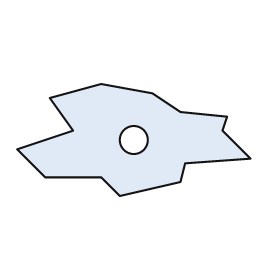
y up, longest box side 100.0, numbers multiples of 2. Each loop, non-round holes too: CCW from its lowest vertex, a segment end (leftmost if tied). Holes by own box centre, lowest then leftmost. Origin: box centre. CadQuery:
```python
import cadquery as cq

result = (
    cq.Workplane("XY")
    .moveTo(-6.0, -24.0)
    .lineTo(20.0, -18.0)
    .lineTo(22.0, -10.0)
    .lineTo(50.0, -8.0)
    .lineTo(38.0, 4.0)
    .lineTo(40.0, 10.0)
    .lineTo(20.0, 12.0)
    .lineTo(8.0, 20.0)
    .lineTo(-14.0, 24.0)
    .lineTo(-36.0, 18.0)
    .lineTo(-26.0, 4.0)
    .lineTo(-50.0, -4.0)
    .lineTo(-38.0, -16.0)
    .lineTo(-14.0, -16.0)
    .close()
    .moveTo(0.0, 0.0)
    .circle(6.0)
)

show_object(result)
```